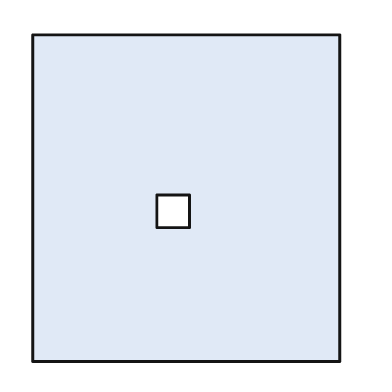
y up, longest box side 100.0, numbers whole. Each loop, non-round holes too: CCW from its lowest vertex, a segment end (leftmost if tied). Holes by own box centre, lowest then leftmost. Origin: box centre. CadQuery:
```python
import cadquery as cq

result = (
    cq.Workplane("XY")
    .moveTo(-47.0, -50.0)
    .lineTo(47.0, -50.0)
    .lineTo(47.0, 50.0)
    .lineTo(-47.0, 50.0)
    .close()
    .moveTo(-9.0, -9.0)
    .lineTo(1.0, -9.0)
    .lineTo(1.0, 1.0)
    .lineTo(-9.0, 1.0)
    .close()
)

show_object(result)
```